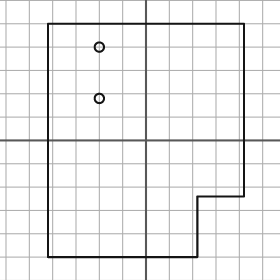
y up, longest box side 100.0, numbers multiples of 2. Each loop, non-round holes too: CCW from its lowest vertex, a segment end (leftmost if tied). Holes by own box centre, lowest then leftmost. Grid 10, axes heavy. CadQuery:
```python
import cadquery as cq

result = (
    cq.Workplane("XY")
    .moveTo(-42.0, -50.0)
    .lineTo(22.0, -50.0)
    .lineTo(22.0, -24.0)
    .lineTo(42.0, -24.0)
    .lineTo(42.0, 50.0)
    .lineTo(-42.0, 50.0)
    .close()
    .moveTo(-20.0, 18.0)
    .circle(2.0)
    .moveTo(-20.0, 40.0)
    .circle(2.0)
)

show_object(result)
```